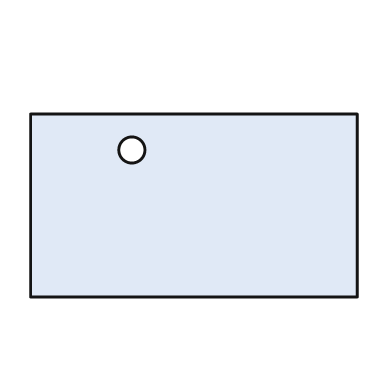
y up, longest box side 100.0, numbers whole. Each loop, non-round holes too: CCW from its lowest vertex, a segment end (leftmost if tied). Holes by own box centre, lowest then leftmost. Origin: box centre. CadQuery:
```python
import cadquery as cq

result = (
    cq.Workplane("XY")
    .moveTo(-50.0, -28.0)
    .lineTo(50.0, -28.0)
    .lineTo(50.0, 28.0)
    .lineTo(-50.0, 28.0)
    .close()
    .moveTo(-19.0, 17.0)
    .circle(4.0)
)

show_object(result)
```